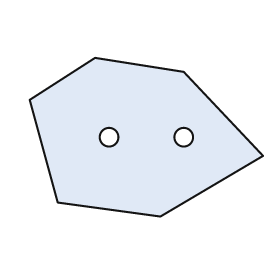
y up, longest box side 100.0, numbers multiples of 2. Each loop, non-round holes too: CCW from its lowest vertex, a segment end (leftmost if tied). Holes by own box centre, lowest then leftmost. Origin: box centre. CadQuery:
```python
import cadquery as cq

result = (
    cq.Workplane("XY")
    .moveTo(6.0, -34.0)
    .lineTo(50.0, -8.0)
    .lineTo(16.0, 28.0)
    .lineTo(-22.0, 34.0)
    .lineTo(-50.0, 16.0)
    .lineTo(-38.0, -28.0)
    .close()
    .moveTo(-16.0, 0.0)
    .circle(4.0)
    .moveTo(16.0, 0.0)
    .circle(4.0)
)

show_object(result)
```